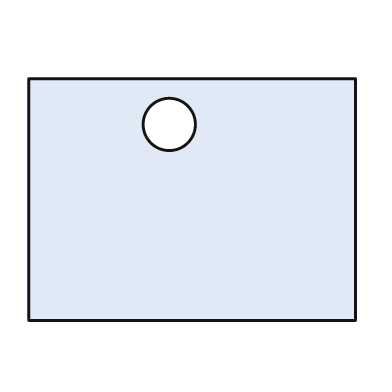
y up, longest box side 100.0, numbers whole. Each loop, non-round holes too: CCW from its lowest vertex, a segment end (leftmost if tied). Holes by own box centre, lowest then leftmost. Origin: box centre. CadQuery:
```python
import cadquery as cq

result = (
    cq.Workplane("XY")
    .moveTo(-50.0, -37.0)
    .lineTo(50.0, -37.0)
    .lineTo(50.0, 37.0)
    .lineTo(-50.0, 37.0)
    .close()
    .moveTo(-7.0, 23.0)
    .circle(8.0)
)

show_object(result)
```